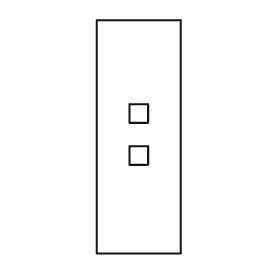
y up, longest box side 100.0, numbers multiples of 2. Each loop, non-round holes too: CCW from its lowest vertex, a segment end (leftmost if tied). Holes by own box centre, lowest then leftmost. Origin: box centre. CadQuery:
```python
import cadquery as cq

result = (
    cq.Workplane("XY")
    .moveTo(-18.0, -50.0)
    .lineTo(18.0, -50.0)
    .lineTo(18.0, 50.0)
    .lineTo(-18.0, 50.0)
    .close()
    .moveTo(-4.0, -12.0)
    .lineTo(4.0, -12.0)
    .lineTo(4.0, -4.0)
    .lineTo(-4.0, -4.0)
    .close()
    .moveTo(-4.0, 6.0)
    .lineTo(4.0, 6.0)
    .lineTo(4.0, 14.0)
    .lineTo(-4.0, 14.0)
    .close()
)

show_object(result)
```